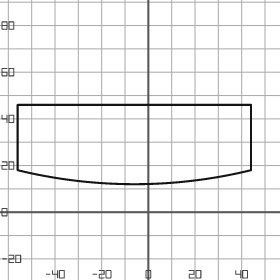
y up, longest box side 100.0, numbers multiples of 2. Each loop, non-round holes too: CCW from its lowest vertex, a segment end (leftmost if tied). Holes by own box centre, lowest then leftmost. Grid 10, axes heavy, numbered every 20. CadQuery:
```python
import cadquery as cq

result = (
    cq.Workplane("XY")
    .moveTo(-56.0, 18.0)
    .threePointArc((-6.0, 12.0), (44.0, 18.0))
    .lineTo(44.0, 46.0)
    .lineTo(-56.0, 46.0)
    .close()
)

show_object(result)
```